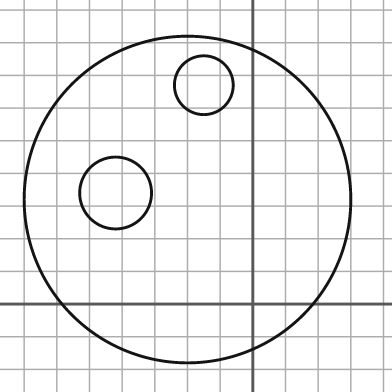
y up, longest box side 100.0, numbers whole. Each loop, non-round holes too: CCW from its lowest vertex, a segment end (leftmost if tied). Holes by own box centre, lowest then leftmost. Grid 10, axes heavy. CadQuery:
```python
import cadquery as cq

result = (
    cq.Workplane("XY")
    .moveTo(-20.0, 32.0)
    .circle(50.0)
    .moveTo(-42.0, 34.0)
    .circle(11.0)
    .moveTo(-15.0, 67.0)
    .circle(9.0)
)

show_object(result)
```